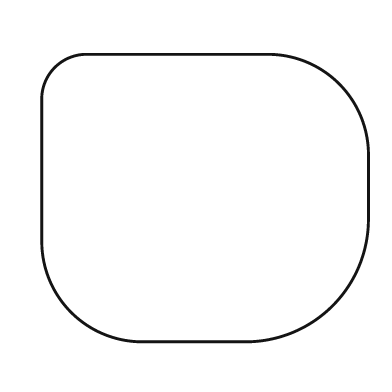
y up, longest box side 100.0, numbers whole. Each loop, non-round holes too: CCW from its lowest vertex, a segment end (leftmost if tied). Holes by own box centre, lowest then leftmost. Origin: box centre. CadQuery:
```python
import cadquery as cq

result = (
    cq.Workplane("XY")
    .moveTo(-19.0, -44.0)
    .lineTo(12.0, -44.0)
    .threePointArc((39.0, -33.0), (50.0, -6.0))
    .lineTo(50.0, 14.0)
    .threePointArc((41.0, 35.0), (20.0, 44.0))
    .lineTo(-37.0, 44.0)
    .threePointArc((-46.0, 40.0), (-50.0, 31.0))
    .lineTo(-50.0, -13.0)
    .threePointArc((-41.0, -35.0), (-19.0, -44.0))
    .close()
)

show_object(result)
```